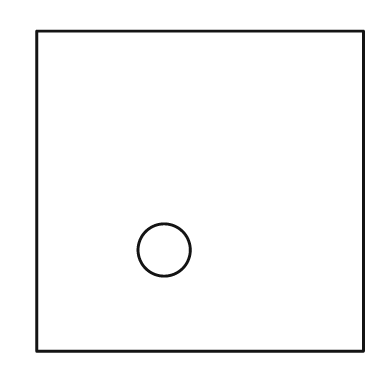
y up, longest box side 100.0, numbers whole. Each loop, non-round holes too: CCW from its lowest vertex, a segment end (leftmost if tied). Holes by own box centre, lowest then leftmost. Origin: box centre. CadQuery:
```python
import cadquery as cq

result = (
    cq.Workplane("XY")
    .moveTo(-50.0, -49.0)
    .lineTo(50.0, -49.0)
    .lineTo(50.0, 49.0)
    .lineTo(-50.0, 49.0)
    .close()
    .moveTo(-11.0, -18.0)
    .circle(8.0)
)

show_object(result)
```